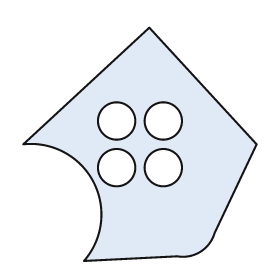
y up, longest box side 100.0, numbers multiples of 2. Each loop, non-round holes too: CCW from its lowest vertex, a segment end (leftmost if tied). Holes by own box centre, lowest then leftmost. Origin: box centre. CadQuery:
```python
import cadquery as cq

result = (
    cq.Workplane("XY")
    .moveTo(-24.0, -50.0)
    .lineTo(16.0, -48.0)
    .threePointArc((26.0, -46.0), (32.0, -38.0))
    .lineTo(50.0, 0.0)
    .lineTo(4.0, 50.0)
    .lineTo(-50.0, 0.0)
    .threePointArc((-20.0, -16.0), (-24.0, -50.0))
    .close()
    .moveTo(-10.0, -10.0)
    .circle(8.0)
    .moveTo(10.0, -10.0)
    .circle(8.0)
    .moveTo(-10.0, 10.0)
    .circle(8.0)
    .moveTo(10.0, 10.0)
    .circle(8.0)
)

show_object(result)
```